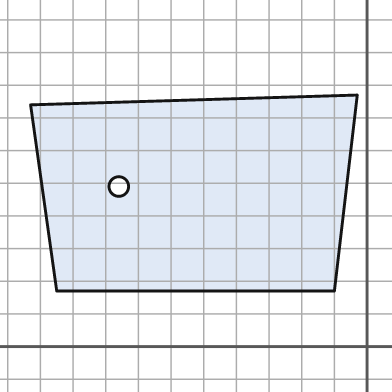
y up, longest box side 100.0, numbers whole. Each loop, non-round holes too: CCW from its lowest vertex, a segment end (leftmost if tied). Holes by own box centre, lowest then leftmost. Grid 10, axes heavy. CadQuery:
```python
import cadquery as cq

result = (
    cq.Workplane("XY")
    .moveTo(-95.0, 17.0)
    .lineTo(-10.0, 17.0)
    .lineTo(-3.0, 77.0)
    .lineTo(-103.0, 74.0)
    .close()
    .moveTo(-76.0, 49.0)
    .circle(3.0)
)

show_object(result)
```